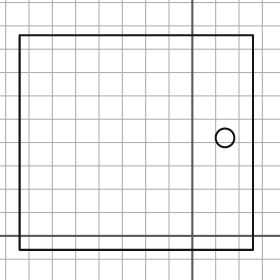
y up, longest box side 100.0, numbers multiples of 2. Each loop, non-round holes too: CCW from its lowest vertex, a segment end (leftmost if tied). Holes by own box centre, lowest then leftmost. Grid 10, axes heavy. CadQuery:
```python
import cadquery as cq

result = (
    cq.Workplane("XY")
    .moveTo(-74.0, -6.0)
    .lineTo(26.0, -6.0)
    .lineTo(26.0, 86.0)
    .lineTo(-74.0, 86.0)
    .close()
    .moveTo(14.0, 42.0)
    .circle(4.0)
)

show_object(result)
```